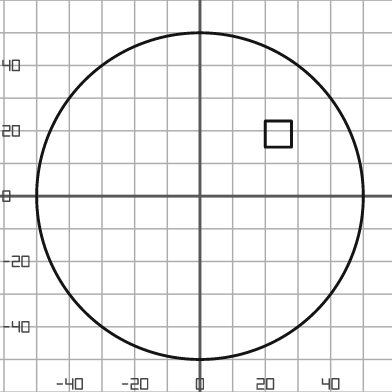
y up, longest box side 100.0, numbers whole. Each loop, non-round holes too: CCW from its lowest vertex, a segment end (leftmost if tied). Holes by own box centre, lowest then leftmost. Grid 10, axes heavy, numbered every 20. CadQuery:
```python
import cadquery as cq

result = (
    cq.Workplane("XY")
    .moveTo(0.0, 0.0)
    .circle(50.0)
    .moveTo(20.0, 15.0)
    .lineTo(28.0, 15.0)
    .lineTo(28.0, 23.0)
    .lineTo(20.0, 23.0)
    .close()
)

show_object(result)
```